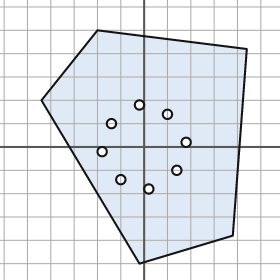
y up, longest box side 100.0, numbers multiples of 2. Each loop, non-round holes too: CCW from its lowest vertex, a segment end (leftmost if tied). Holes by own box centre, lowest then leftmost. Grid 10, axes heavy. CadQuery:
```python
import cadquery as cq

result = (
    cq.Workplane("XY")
    .moveTo(-2.0, -50.0)
    .lineTo(38.0, -38.0)
    .lineTo(44.0, 42.0)
    .lineTo(-20.0, 50.0)
    .lineTo(-44.0, 20.0)
    .close()
    .moveTo(2.0, -18.0)
    .circle(2.0)
    .moveTo(-10.0, -14.0)
    .circle(2.0)
    .moveTo(14.0, -10.0)
    .circle(2.0)
    .moveTo(-18.0, -2.0)
    .circle(2.0)
    .moveTo(18.0, 2.0)
    .circle(2.0)
    .moveTo(-14.0, 10.0)
    .circle(2.0)
    .moveTo(10.0, 14.0)
    .circle(2.0)
    .moveTo(-2.0, 18.0)
    .circle(2.0)
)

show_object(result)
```